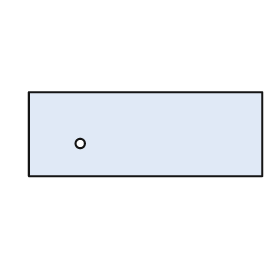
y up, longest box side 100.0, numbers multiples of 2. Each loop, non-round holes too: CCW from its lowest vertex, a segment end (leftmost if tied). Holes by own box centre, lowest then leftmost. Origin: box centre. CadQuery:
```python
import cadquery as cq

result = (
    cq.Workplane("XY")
    .moveTo(-50.0, -18.0)
    .lineTo(50.0, -18.0)
    .lineTo(50.0, 18.0)
    .lineTo(-50.0, 18.0)
    .close()
    .moveTo(-28.0, -4.0)
    .circle(2.0)
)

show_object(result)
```